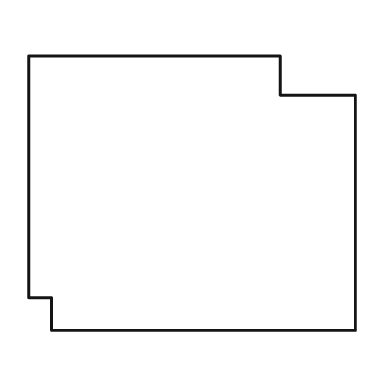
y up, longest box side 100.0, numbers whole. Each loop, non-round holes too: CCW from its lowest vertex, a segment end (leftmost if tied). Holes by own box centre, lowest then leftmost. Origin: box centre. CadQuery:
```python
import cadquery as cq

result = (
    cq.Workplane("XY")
    .moveTo(-43.0, -42.0)
    .lineTo(50.0, -42.0)
    .lineTo(50.0, 30.0)
    .lineTo(27.0, 30.0)
    .lineTo(27.0, 42.0)
    .lineTo(-50.0, 42.0)
    .lineTo(-50.0, -32.0)
    .lineTo(-43.0, -32.0)
    .close()
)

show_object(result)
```